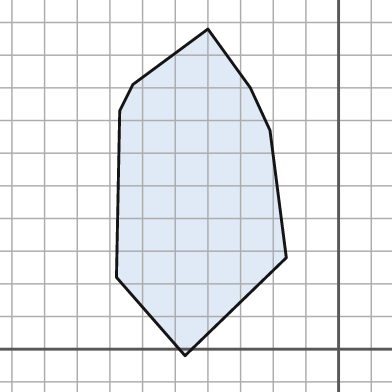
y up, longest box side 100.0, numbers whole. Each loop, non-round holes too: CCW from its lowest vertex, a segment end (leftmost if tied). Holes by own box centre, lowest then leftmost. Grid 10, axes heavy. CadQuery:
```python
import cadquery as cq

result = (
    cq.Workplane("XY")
    .moveTo(-47.0, -2.0)
    .lineTo(-16.0, 28.0)
    .lineTo(-21.0, 67.0)
    .lineTo(-27.0, 80.0)
    .lineTo(-40.0, 98.0)
    .lineTo(-63.0, 81.0)
    .lineTo(-67.0, 73.0)
    .lineTo(-68.0, 22.0)
    .close()
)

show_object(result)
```